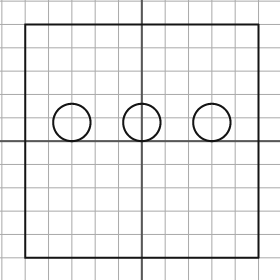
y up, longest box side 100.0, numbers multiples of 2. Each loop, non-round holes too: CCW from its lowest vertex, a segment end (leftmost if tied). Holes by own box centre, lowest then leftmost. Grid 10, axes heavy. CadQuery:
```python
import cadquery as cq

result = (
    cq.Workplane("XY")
    .moveTo(-50.0, -50.0)
    .lineTo(50.0, -50.0)
    .lineTo(50.0, 50.0)
    .lineTo(-50.0, 50.0)
    .close()
    .moveTo(-30.0, 8.0)
    .circle(8.0)
    .moveTo(0.0, 8.0)
    .circle(8.0)
    .moveTo(30.0, 8.0)
    .circle(8.0)
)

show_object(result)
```